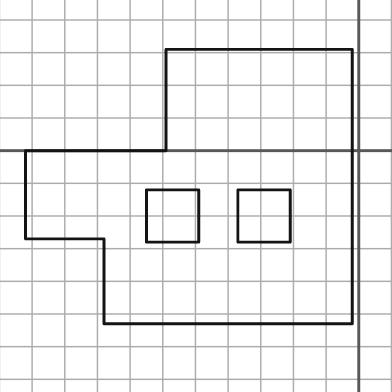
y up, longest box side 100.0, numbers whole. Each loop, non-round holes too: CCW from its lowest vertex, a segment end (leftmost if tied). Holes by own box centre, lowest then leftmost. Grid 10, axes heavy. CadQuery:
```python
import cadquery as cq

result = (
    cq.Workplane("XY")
    .moveTo(-78.0, -53.0)
    .lineTo(-2.0, -53.0)
    .lineTo(-2.0, 31.0)
    .lineTo(-59.0, 31.0)
    .lineTo(-59.0, 0.0)
    .lineTo(-102.0, 0.0)
    .lineTo(-102.0, -27.0)
    .lineTo(-78.0, -27.0)
    .close()
    .moveTo(-65.0, -28.0)
    .lineTo(-49.0, -28.0)
    .lineTo(-49.0, -12.0)
    .lineTo(-65.0, -12.0)
    .close()
    .moveTo(-37.0, -28.0)
    .lineTo(-21.0, -28.0)
    .lineTo(-21.0, -12.0)
    .lineTo(-37.0, -12.0)
    .close()
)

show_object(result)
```